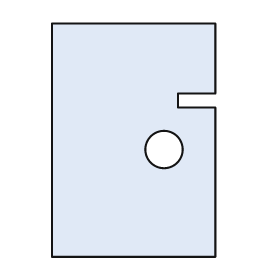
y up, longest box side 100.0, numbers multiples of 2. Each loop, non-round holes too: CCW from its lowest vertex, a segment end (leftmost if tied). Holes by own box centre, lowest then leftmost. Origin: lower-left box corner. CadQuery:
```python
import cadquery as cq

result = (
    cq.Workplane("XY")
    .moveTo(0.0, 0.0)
    .lineTo(70.0, 0.0)
    .lineTo(70.0, 64.0)
    .lineTo(54.0, 64.0)
    .lineTo(54.0, 70.0)
    .lineTo(70.0, 70.0)
    .lineTo(70.0, 100.0)
    .lineTo(0.0, 100.0)
    .close()
    .moveTo(48.0, 46.0)
    .circle(8.0)
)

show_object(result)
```